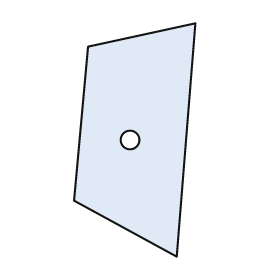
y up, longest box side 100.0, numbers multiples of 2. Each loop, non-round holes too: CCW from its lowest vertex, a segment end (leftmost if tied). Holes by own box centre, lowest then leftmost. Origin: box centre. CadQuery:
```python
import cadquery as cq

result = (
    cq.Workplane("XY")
    .moveTo(18.0, -50.0)
    .lineTo(26.0, 50.0)
    .lineTo(-20.0, 40.0)
    .lineTo(-26.0, -26.0)
    .close()
    .moveTo(-2.0, 0.0)
    .circle(4.0)
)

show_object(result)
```